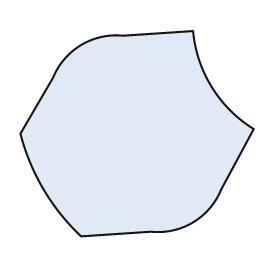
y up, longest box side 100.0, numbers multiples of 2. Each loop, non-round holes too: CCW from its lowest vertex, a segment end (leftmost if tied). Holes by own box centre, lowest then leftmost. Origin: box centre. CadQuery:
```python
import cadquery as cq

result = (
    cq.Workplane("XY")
    .moveTo(-24.0, -44.0)
    .lineTo(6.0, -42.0)
    .threePointArc((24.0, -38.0), (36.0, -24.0))
    .lineTo(50.0, 2.0)
    .threePointArc((32.0, 20.0), (24.0, 44.0))
    .lineTo(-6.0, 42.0)
    .threePointArc((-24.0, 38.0), (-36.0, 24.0))
    .lineTo(-50.0, 0.0)
    .threePointArc((-40.0, -24.0), (-24.0, -44.0))
    .close()
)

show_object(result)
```